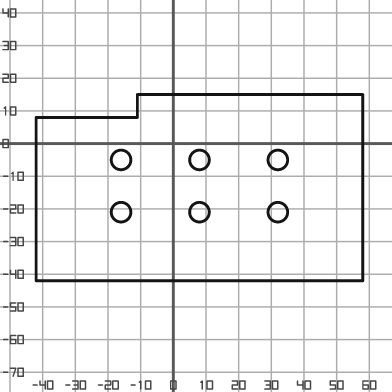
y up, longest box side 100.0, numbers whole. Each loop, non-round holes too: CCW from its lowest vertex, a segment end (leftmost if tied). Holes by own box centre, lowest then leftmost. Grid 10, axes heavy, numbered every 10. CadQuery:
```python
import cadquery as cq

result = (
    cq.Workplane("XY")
    .moveTo(-42.0, -42.0)
    .lineTo(58.0, -42.0)
    .lineTo(58.0, 15.0)
    .lineTo(-11.0, 15.0)
    .lineTo(-11.0, 8.0)
    .lineTo(-42.0, 8.0)
    .close()
    .moveTo(-16.0, -21.0)
    .circle(3.0)
    .moveTo(8.0, -21.0)
    .circle(3.0)
    .moveTo(32.0, -21.0)
    .circle(3.0)
    .moveTo(-16.0, -5.0)
    .circle(3.0)
    .moveTo(8.0, -5.0)
    .circle(3.0)
    .moveTo(32.0, -5.0)
    .circle(3.0)
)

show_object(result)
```